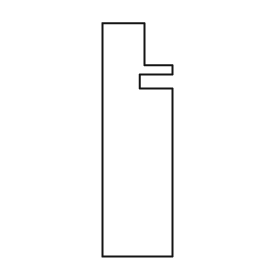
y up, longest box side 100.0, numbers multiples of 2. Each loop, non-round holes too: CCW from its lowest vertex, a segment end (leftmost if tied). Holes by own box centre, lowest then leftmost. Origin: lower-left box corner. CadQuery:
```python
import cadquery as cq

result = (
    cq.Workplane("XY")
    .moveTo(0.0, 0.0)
    .lineTo(30.0, 0.0)
    .lineTo(30.0, 72.0)
    .lineTo(16.0, 72.0)
    .lineTo(16.0, 78.0)
    .lineTo(30.0, 78.0)
    .lineTo(30.0, 82.0)
    .lineTo(18.0, 82.0)
    .lineTo(18.0, 100.0)
    .lineTo(0.0, 100.0)
    .close()
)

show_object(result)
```